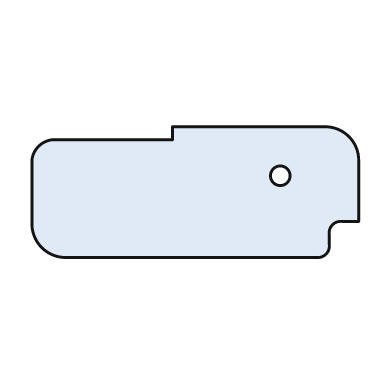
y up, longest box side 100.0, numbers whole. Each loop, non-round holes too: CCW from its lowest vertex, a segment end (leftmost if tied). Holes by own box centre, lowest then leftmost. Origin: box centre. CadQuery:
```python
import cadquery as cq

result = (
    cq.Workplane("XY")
    .moveTo(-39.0, -20.0)
    .lineTo(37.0, -20.0)
    .threePointArc((40.0, -19.0), (41.0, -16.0))
    .lineTo(41.0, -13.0)
    .threePointArc((42.0, -10.0), (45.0, -9.0))
    .lineTo(50.0, -9.0)
    .lineTo(50.0, 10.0)
    .threePointArc((47.0, 17.0), (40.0, 20.0))
    .lineTo(-7.0, 20.0)
    .lineTo(-7.0, 16.0)
    .lineTo(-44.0, 16.0)
    .threePointArc((-48.0, 14.0), (-50.0, 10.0))
    .lineTo(-50.0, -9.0)
    .threePointArc((-47.0, -17.0), (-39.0, -20.0))
    .close()
    .moveTo(26.0, 5.0)
    .circle(3.0)
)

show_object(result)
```